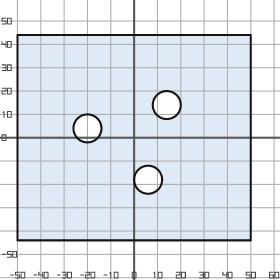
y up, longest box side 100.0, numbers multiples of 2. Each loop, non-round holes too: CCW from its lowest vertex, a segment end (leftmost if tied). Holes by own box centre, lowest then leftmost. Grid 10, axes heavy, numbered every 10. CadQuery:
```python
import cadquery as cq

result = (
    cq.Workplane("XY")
    .moveTo(-50.0, -44.0)
    .lineTo(50.0, -44.0)
    .lineTo(50.0, 44.0)
    .lineTo(-50.0, 44.0)
    .close()
    .moveTo(6.0, -18.0)
    .circle(6.0)
    .moveTo(-20.0, 4.0)
    .circle(6.0)
    .moveTo(14.0, 14.0)
    .circle(6.0)
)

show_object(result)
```